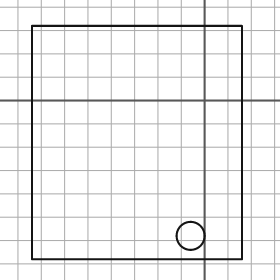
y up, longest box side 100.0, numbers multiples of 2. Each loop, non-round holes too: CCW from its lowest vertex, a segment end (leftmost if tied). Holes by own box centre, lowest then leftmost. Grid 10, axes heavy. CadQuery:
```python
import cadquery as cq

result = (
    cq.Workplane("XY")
    .moveTo(-74.0, -68.0)
    .lineTo(16.0, -68.0)
    .lineTo(16.0, 32.0)
    .lineTo(-74.0, 32.0)
    .close()
    .moveTo(-6.0, -58.0)
    .circle(6.0)
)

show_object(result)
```